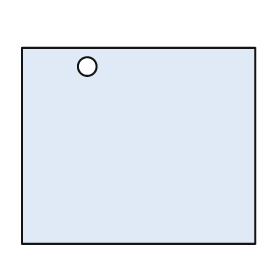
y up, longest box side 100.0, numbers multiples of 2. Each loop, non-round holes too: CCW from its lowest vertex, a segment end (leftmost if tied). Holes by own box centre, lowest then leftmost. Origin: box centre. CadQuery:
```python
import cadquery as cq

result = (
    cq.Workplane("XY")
    .moveTo(-50.0, -42.0)
    .lineTo(50.0, -42.0)
    .lineTo(50.0, 42.0)
    .lineTo(-50.0, 42.0)
    .close()
    .moveTo(-22.0, 34.0)
    .circle(4.0)
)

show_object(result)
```